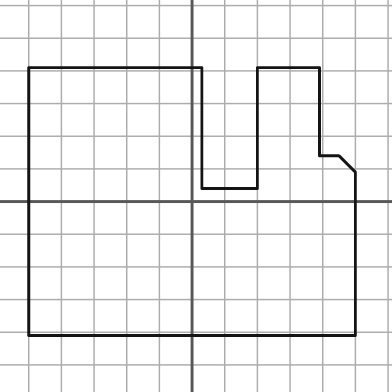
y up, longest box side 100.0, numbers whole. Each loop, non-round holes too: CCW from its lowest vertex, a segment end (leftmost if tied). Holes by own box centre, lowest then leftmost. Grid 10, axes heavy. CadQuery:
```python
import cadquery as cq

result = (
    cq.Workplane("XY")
    .moveTo(-50.0, -41.0)
    .lineTo(50.0, -41.0)
    .lineTo(50.0, 9.0)
    .lineTo(45.0, 14.0)
    .lineTo(39.0, 14.0)
    .lineTo(39.0, 41.0)
    .lineTo(20.0, 41.0)
    .lineTo(20.0, 4.0)
    .lineTo(3.0, 4.0)
    .lineTo(3.0, 41.0)
    .lineTo(-50.0, 41.0)
    .close()
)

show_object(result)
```